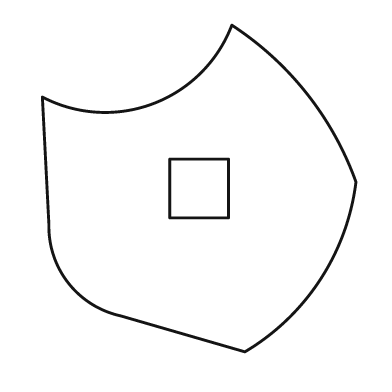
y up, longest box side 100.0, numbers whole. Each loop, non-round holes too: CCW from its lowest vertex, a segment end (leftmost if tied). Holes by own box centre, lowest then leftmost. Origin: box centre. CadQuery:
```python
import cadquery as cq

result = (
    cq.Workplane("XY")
    .moveTo(14.0, -50.0)
    .threePointArc((37.0, -28.0), (48.0, 2.0))
    .threePointArc((33.0, 29.0), (10.0, 50.0))
    .threePointArc((-14.0, 26.0), (-48.0, 28.0))
    .lineTo(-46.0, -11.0)
    .threePointArc((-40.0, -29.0), (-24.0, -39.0))
    .close()
    .moveTo(-9.0, -9.0)
    .lineTo(9.0, -9.0)
    .lineTo(9.0, 9.0)
    .lineTo(-9.0, 9.0)
    .close()
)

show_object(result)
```